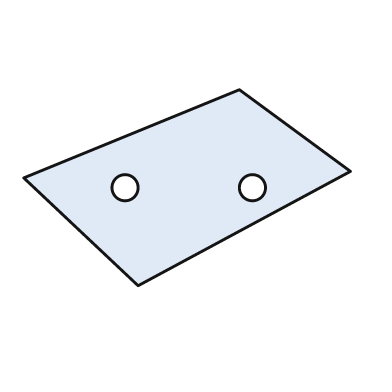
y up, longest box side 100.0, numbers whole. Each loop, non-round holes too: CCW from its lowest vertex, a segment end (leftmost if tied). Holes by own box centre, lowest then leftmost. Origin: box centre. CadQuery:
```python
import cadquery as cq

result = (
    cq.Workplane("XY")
    .moveTo(-15.0, -30.0)
    .lineTo(50.0, 5.0)
    .lineTo(16.0, 30.0)
    .lineTo(-50.0, 3.0)
    .close()
    .moveTo(-19.0, 0.0)
    .circle(4.0)
    .moveTo(20.0, 0.0)
    .circle(4.0)
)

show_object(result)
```